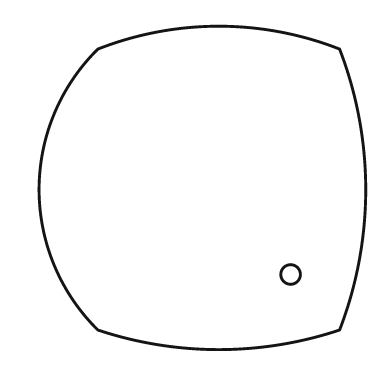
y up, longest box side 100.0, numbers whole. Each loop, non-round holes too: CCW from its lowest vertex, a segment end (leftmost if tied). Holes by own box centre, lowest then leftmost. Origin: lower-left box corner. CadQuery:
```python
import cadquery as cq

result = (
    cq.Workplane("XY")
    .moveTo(18.0, 6.0)
    .threePointArc((55.0, 0.0), (92.0, 6.0))
    .threePointArc((100.0, 49.0), (92.0, 92.0))
    .threePointArc((55.0, 99.0), (18.0, 92.0))
    .threePointArc((0.0, 49.0), (18.0, 6.0))
    .close()
    .moveTo(77.0, 23.0)
    .circle(3.0)
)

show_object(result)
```